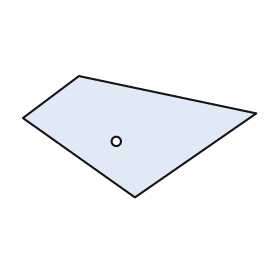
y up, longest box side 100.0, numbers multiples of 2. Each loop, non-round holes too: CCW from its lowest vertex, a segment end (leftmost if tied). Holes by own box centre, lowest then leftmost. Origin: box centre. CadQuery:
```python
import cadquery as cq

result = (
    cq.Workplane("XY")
    .moveTo(-2.0, -26.0)
    .lineTo(50.0, 10.0)
    .lineTo(-26.0, 26.0)
    .lineTo(-50.0, 8.0)
    .close()
    .moveTo(-10.0, -2.0)
    .circle(2.0)
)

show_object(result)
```